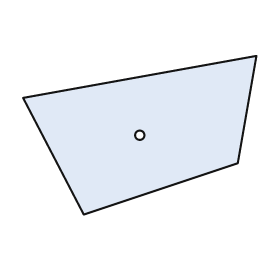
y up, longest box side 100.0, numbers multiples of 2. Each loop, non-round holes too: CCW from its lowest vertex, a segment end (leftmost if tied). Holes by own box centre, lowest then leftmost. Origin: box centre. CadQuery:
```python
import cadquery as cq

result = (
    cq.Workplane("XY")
    .moveTo(-24.0, -34.0)
    .lineTo(42.0, -12.0)
    .lineTo(50.0, 34.0)
    .lineTo(-50.0, 16.0)
    .close()
    .moveTo(0.0, 0.0)
    .circle(2.0)
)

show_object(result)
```